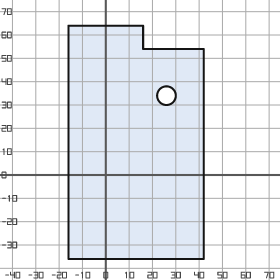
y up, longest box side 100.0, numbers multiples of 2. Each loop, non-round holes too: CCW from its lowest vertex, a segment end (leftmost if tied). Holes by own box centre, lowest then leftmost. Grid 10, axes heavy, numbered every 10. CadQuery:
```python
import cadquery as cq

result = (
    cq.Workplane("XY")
    .moveTo(-16.0, -36.0)
    .lineTo(42.0, -36.0)
    .lineTo(42.0, 54.0)
    .lineTo(16.0, 54.0)
    .lineTo(16.0, 64.0)
    .lineTo(-16.0, 64.0)
    .close()
    .moveTo(26.0, 34.0)
    .circle(4.0)
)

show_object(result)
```